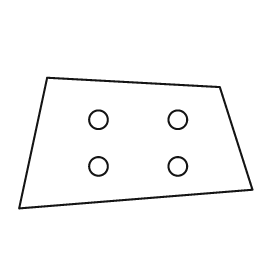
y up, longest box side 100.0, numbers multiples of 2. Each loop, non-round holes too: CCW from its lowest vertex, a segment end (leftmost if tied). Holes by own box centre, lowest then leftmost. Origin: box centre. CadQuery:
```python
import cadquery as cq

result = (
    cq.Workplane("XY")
    .moveTo(-50.0, -28.0)
    .lineTo(50.0, -20.0)
    .lineTo(36.0, 24.0)
    .lineTo(-38.0, 28.0)
    .close()
    .moveTo(-16.0, -10.0)
    .circle(4.0)
    .moveTo(18.0, -10.0)
    .circle(4.0)
    .moveTo(-16.0, 10.0)
    .circle(4.0)
    .moveTo(18.0, 10.0)
    .circle(4.0)
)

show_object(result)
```